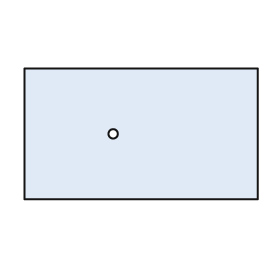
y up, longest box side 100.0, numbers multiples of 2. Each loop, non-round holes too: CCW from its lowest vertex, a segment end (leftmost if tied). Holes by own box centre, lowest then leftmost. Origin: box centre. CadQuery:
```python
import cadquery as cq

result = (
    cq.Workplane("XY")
    .moveTo(-50.0, -28.0)
    .lineTo(50.0, -28.0)
    .lineTo(50.0, 28.0)
    .lineTo(-50.0, 28.0)
    .close()
    .moveTo(-12.0, 0.0)
    .circle(2.0)
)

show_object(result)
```